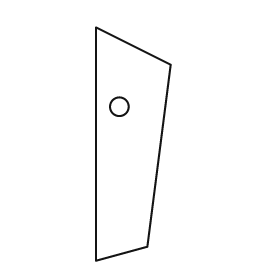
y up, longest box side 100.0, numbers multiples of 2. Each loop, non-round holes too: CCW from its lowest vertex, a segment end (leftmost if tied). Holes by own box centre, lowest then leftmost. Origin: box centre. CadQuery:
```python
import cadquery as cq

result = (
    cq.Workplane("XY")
    .moveTo(-16.0, -50.0)
    .lineTo(6.0, -44.0)
    .lineTo(16.0, 34.0)
    .lineTo(-16.0, 50.0)
    .close()
    .moveTo(-6.0, 16.0)
    .circle(4.0)
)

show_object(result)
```